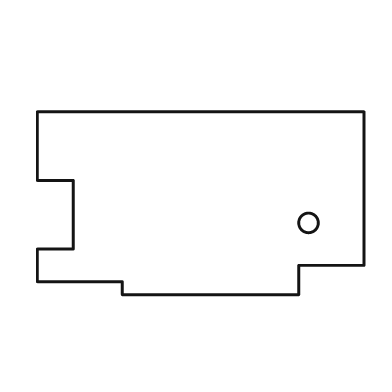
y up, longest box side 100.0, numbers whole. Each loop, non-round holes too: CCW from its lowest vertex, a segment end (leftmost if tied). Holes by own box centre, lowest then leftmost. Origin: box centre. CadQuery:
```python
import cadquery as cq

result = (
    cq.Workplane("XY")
    .moveTo(-24.0, -28.0)
    .lineTo(30.0, -28.0)
    .lineTo(30.0, -19.0)
    .lineTo(50.0, -19.0)
    .lineTo(50.0, 28.0)
    .lineTo(-50.0, 28.0)
    .lineTo(-50.0, 7.0)
    .lineTo(-39.0, 7.0)
    .lineTo(-39.0, -14.0)
    .lineTo(-50.0, -14.0)
    .lineTo(-50.0, -24.0)
    .lineTo(-24.0, -24.0)
    .close()
    .moveTo(33.0, -6.0)
    .circle(3.0)
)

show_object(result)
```